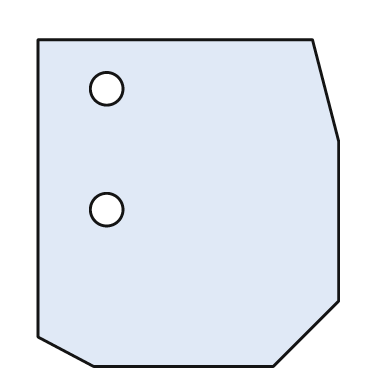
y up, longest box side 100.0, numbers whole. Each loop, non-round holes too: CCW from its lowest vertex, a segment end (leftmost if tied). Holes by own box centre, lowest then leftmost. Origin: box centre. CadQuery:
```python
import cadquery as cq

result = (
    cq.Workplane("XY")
    .moveTo(-29.0, -50.0)
    .lineTo(26.0, -50.0)
    .lineTo(46.0, -30.0)
    .lineTo(46.0, 19.0)
    .lineTo(38.0, 50.0)
    .lineTo(-46.0, 50.0)
    .lineTo(-46.0, -41.0)
    .close()
    .moveTo(-25.0, -2.0)
    .circle(5.0)
    .moveTo(-25.0, 35.0)
    .circle(5.0)
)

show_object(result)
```